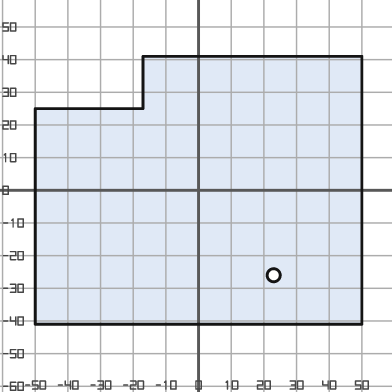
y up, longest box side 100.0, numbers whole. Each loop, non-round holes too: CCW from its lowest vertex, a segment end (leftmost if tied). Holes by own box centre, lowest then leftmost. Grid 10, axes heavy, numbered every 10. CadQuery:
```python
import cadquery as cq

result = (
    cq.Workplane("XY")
    .moveTo(-50.0, -41.0)
    .lineTo(50.0, -41.0)
    .lineTo(50.0, 41.0)
    .lineTo(-17.0, 41.0)
    .lineTo(-17.0, 25.0)
    .lineTo(-50.0, 25.0)
    .close()
    .moveTo(23.0, -26.0)
    .circle(2.0)
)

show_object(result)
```